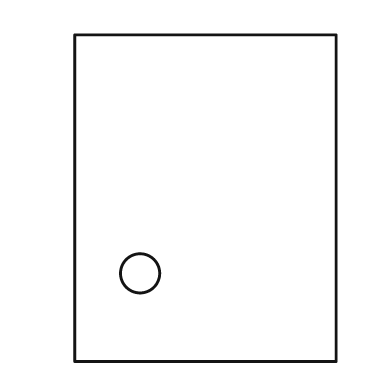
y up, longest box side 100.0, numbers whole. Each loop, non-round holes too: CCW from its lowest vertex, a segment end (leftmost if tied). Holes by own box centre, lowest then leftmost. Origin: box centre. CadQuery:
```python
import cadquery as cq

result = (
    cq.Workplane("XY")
    .moveTo(-40.0, -50.0)
    .lineTo(40.0, -50.0)
    .lineTo(40.0, 50.0)
    .lineTo(-40.0, 50.0)
    .close()
    .moveTo(-20.0, -23.0)
    .circle(6.0)
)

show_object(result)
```